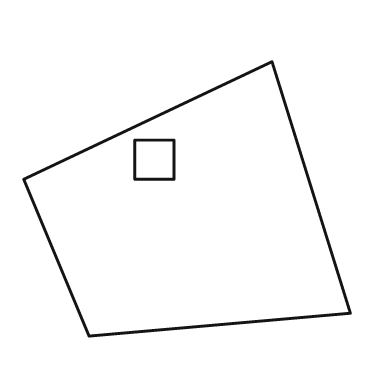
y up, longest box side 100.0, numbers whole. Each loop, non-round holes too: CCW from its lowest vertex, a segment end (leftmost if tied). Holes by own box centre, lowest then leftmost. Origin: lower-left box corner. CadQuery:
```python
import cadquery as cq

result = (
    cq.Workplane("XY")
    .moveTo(20.0, 0.0)
    .lineTo(100.0, 7.0)
    .lineTo(76.0, 84.0)
    .lineTo(0.0, 48.0)
    .close()
    .moveTo(34.0, 48.0)
    .lineTo(46.0, 48.0)
    .lineTo(46.0, 60.0)
    .lineTo(34.0, 60.0)
    .close()
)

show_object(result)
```